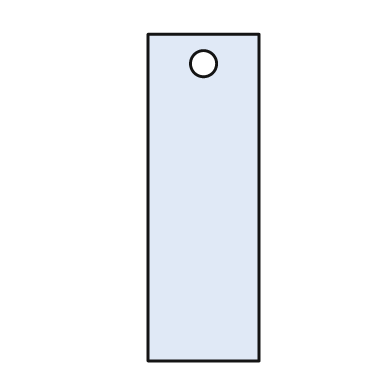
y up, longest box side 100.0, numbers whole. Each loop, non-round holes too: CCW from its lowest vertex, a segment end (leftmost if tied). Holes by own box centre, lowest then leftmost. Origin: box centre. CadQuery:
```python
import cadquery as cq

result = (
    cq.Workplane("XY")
    .moveTo(-17.0, -50.0)
    .lineTo(17.0, -50.0)
    .lineTo(17.0, 50.0)
    .lineTo(-17.0, 50.0)
    .close()
    .moveTo(0.0, 41.0)
    .circle(4.0)
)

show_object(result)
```